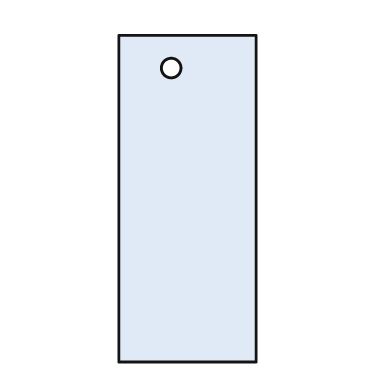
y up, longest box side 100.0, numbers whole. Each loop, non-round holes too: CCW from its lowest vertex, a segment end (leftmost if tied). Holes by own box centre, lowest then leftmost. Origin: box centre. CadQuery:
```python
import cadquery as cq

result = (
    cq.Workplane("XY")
    .moveTo(-21.0, -50.0)
    .lineTo(21.0, -50.0)
    .lineTo(21.0, 50.0)
    .lineTo(-21.0, 50.0)
    .close()
    .moveTo(-5.0, 40.0)
    .circle(3.0)
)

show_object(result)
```